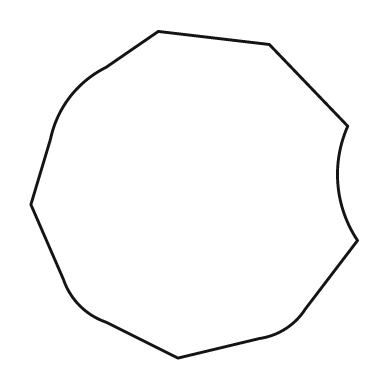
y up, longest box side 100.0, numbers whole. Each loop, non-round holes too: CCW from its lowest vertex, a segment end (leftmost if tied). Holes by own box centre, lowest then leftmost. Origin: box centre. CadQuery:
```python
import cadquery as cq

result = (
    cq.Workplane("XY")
    .moveTo(-5.0, -50.0)
    .lineTo(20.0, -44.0)
    .threePointArc((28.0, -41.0), (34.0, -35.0))
    .lineTo(50.0, -14.0)
    .threePointArc((44.0, 3.0), (47.0, 21.0))
    .lineTo(23.0, 46.0)
    .lineTo(-11.0, 50.0)
    .lineTo(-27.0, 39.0)
    .threePointArc((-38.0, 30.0), (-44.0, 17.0))
    .lineTo(-50.0, -3.0)
    .lineTo(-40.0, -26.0)
    .threePointArc((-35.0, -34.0), (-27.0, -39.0))
    .close()
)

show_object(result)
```